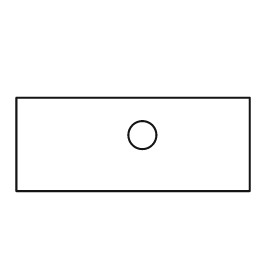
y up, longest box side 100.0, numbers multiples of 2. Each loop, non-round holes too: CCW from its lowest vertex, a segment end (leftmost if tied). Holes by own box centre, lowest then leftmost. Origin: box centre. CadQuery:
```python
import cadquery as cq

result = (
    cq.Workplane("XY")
    .moveTo(-50.0, -20.0)
    .lineTo(50.0, -20.0)
    .lineTo(50.0, 20.0)
    .lineTo(-50.0, 20.0)
    .close()
    .moveTo(4.0, 4.0)
    .circle(6.0)
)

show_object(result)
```